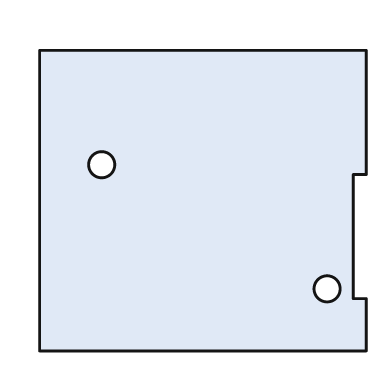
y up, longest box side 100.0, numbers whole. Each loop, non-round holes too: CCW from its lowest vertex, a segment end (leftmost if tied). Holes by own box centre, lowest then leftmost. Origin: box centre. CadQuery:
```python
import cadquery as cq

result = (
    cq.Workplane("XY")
    .moveTo(-50.0, -46.0)
    .lineTo(50.0, -46.0)
    .lineTo(50.0, -30.0)
    .lineTo(46.0, -30.0)
    .lineTo(46.0, 8.0)
    .lineTo(50.0, 8.0)
    .lineTo(50.0, 46.0)
    .lineTo(-50.0, 46.0)
    .close()
    .moveTo(38.0, -27.0)
    .circle(4.0)
    .moveTo(-31.0, 11.0)
    .circle(4.0)
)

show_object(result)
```